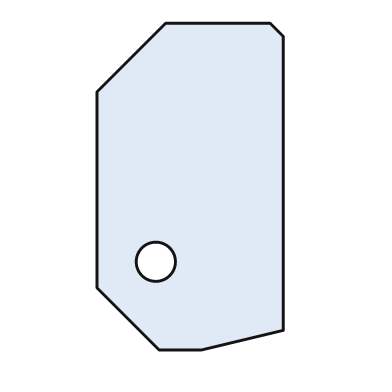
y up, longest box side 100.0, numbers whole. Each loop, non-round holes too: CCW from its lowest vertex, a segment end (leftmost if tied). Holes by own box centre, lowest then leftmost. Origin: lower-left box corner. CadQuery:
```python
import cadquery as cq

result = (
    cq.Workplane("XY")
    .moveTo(19.0, 0.0)
    .lineTo(32.0, 0.0)
    .lineTo(57.0, 6.0)
    .lineTo(57.0, 96.0)
    .lineTo(53.0, 100.0)
    .lineTo(21.0, 100.0)
    .lineTo(0.0, 79.0)
    .lineTo(0.0, 19.0)
    .close()
    .moveTo(18.0, 27.0)
    .circle(6.0)
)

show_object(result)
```